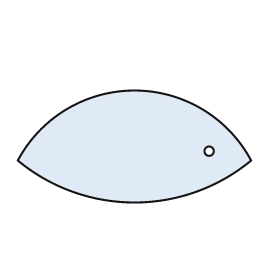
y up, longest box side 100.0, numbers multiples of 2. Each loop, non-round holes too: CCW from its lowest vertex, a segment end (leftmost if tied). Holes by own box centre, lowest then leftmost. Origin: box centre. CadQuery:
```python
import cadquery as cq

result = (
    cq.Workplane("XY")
    .moveTo(-50.0, -6.0)
    .threePointArc((0.0, -24.0), (50.0, -6.0))
    .threePointArc((0.0, 24.0), (-50.0, -6.0))
    .close()
    .moveTo(32.0, -2.0)
    .circle(2.0)
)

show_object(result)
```